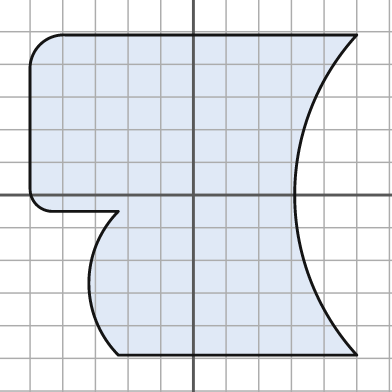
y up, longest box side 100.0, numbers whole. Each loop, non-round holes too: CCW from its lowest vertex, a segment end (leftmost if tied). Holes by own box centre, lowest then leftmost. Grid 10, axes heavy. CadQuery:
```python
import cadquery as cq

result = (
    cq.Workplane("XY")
    .moveTo(-23.0, -49.0)
    .lineTo(50.0, -49.0)
    .threePointArc((31.0, 0.0), (50.0, 49.0))
    .lineTo(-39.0, 49.0)
    .threePointArc((-47.0, 46.0), (-50.0, 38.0))
    .lineTo(-50.0, 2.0)
    .threePointArc((-48.0, -3.0), (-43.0, -5.0))
    .lineTo(-23.0, -5.0)
    .threePointArc((-32.0, -27.0), (-23.0, -49.0))
    .close()
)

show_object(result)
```